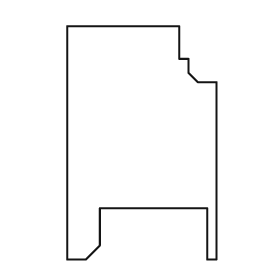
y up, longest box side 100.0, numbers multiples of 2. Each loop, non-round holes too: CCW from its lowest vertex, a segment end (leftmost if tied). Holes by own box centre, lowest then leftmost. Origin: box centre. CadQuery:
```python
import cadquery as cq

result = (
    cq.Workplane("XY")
    .moveTo(-32.0, -50.0)
    .lineTo(-24.0, -50.0)
    .lineTo(-18.0, -44.0)
    .lineTo(-18.0, -28.0)
    .lineTo(28.0, -28.0)
    .lineTo(28.0, -50.0)
    .lineTo(32.0, -50.0)
    .lineTo(32.0, 26.0)
    .lineTo(24.0, 26.0)
    .lineTo(20.0, 30.0)
    .lineTo(20.0, 36.0)
    .lineTo(16.0, 36.0)
    .lineTo(16.0, 50.0)
    .lineTo(-32.0, 50.0)
    .close()
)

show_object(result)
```